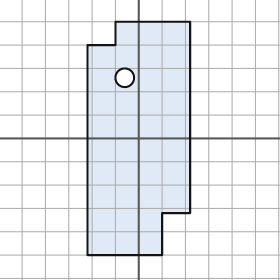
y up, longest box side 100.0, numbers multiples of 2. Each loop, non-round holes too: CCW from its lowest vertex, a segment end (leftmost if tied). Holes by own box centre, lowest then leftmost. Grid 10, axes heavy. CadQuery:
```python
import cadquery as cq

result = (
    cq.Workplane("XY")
    .moveTo(-22.0, -50.0)
    .lineTo(10.0, -50.0)
    .lineTo(10.0, -32.0)
    .lineTo(22.0, -32.0)
    .lineTo(22.0, 50.0)
    .lineTo(-10.0, 50.0)
    .lineTo(-10.0, 40.0)
    .lineTo(-22.0, 40.0)
    .close()
    .moveTo(-6.0, 26.0)
    .circle(4.0)
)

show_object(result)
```